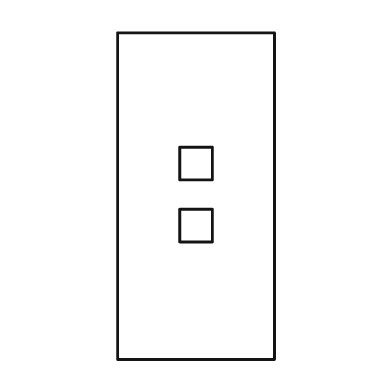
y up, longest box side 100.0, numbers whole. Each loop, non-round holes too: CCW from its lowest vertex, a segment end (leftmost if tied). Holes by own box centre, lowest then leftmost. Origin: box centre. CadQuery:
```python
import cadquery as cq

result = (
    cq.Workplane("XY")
    .moveTo(-24.0, -50.0)
    .lineTo(24.0, -50.0)
    .lineTo(24.0, 50.0)
    .lineTo(-24.0, 50.0)
    .close()
    .moveTo(-5.0, -14.0)
    .lineTo(5.0, -14.0)
    .lineTo(5.0, -4.0)
    .lineTo(-5.0, -4.0)
    .close()
    .moveTo(-5.0, 5.0)
    .lineTo(5.0, 5.0)
    .lineTo(5.0, 15.0)
    .lineTo(-5.0, 15.0)
    .close()
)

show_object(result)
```